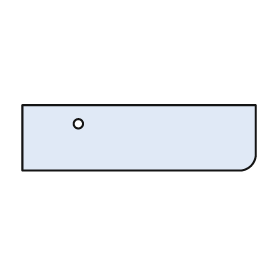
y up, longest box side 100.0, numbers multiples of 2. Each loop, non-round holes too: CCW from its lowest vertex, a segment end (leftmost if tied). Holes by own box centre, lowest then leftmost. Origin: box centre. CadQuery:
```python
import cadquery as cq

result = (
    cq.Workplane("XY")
    .moveTo(-50.0, -14.0)
    .lineTo(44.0, -14.0)
    .threePointArc((48.0, -12.0), (50.0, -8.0))
    .lineTo(50.0, 14.0)
    .lineTo(-50.0, 14.0)
    .close()
    .moveTo(-26.0, 6.0)
    .circle(2.0)
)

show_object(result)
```